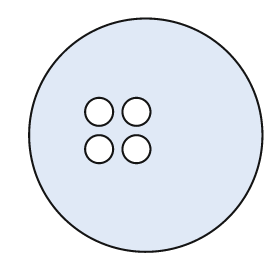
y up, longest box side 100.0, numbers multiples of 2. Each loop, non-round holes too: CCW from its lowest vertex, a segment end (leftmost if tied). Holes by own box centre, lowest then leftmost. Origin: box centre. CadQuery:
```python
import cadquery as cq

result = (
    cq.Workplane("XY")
    .moveTo(0.0, 0.0)
    .circle(50.0)
    .moveTo(-20.0, -6.0)
    .circle(6.0)
    .moveTo(-4.0, -6.0)
    .circle(6.0)
    .moveTo(-20.0, 10.0)
    .circle(6.0)
    .moveTo(-4.0, 10.0)
    .circle(6.0)
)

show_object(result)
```